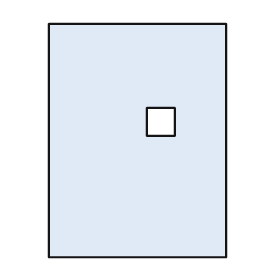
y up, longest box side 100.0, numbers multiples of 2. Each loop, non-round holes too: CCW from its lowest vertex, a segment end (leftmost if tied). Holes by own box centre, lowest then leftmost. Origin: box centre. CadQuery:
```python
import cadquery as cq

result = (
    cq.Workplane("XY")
    .moveTo(-38.0, -50.0)
    .lineTo(38.0, -50.0)
    .lineTo(38.0, 50.0)
    .lineTo(-38.0, 50.0)
    .close()
    .moveTo(4.0, 2.0)
    .lineTo(16.0, 2.0)
    .lineTo(16.0, 14.0)
    .lineTo(4.0, 14.0)
    .close()
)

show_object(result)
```